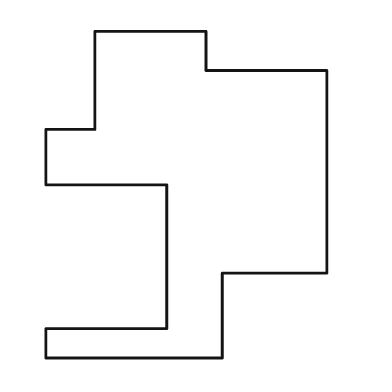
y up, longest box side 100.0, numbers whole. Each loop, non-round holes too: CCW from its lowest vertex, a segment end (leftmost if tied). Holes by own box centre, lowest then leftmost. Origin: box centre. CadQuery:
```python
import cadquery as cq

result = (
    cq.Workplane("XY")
    .moveTo(-43.0, -50.0)
    .lineTo(11.0, -50.0)
    .lineTo(11.0, -24.0)
    .lineTo(43.0, -24.0)
    .lineTo(43.0, 38.0)
    .lineTo(6.0, 38.0)
    .lineTo(6.0, 50.0)
    .lineTo(-28.0, 50.0)
    .lineTo(-28.0, 20.0)
    .lineTo(-43.0, 20.0)
    .lineTo(-43.0, 3.0)
    .lineTo(-6.0, 3.0)
    .lineTo(-6.0, -41.0)
    .lineTo(-43.0, -41.0)
    .close()
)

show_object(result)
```